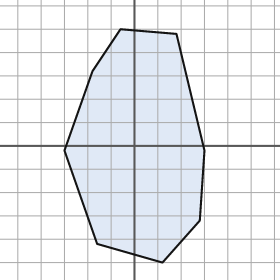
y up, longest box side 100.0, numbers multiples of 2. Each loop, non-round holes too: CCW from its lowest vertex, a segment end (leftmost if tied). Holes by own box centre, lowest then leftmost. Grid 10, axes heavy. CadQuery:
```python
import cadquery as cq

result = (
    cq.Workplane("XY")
    .moveTo(12.0, -50.0)
    .lineTo(28.0, -32.0)
    .lineTo(30.0, -2.0)
    .lineTo(18.0, 48.0)
    .lineTo(-6.0, 50.0)
    .lineTo(-18.0, 32.0)
    .lineTo(-30.0, -2.0)
    .lineTo(-16.0, -42.0)
    .close()
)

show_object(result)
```